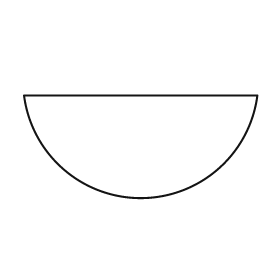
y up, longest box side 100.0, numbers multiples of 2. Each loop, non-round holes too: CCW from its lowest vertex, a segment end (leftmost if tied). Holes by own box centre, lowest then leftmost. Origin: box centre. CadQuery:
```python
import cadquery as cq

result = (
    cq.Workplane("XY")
    .moveTo(-50.0, 22.0)
    .threePointArc((0.0, -22.0), (50.0, 22.0))
    .close()
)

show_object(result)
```